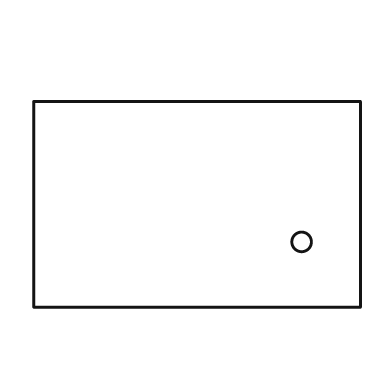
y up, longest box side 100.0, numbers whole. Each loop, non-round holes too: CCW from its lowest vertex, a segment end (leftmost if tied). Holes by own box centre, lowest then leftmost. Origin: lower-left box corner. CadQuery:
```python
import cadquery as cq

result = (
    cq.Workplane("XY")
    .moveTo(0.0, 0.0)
    .lineTo(100.0, 0.0)
    .lineTo(100.0, 63.0)
    .lineTo(0.0, 63.0)
    .close()
    .moveTo(82.0, 20.0)
    .circle(3.0)
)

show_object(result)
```